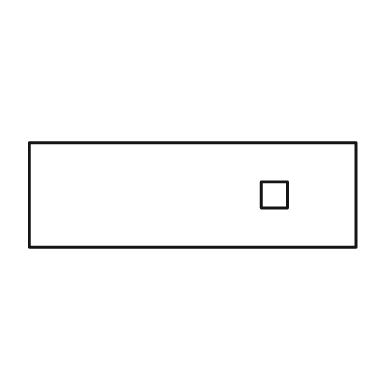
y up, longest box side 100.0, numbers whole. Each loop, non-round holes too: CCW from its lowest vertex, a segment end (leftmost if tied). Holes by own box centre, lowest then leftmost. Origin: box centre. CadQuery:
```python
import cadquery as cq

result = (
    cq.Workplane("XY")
    .moveTo(-50.0, -16.0)
    .lineTo(50.0, -16.0)
    .lineTo(50.0, 16.0)
    .lineTo(-50.0, 16.0)
    .close()
    .moveTo(21.0, -4.0)
    .lineTo(29.0, -4.0)
    .lineTo(29.0, 4.0)
    .lineTo(21.0, 4.0)
    .close()
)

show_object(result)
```